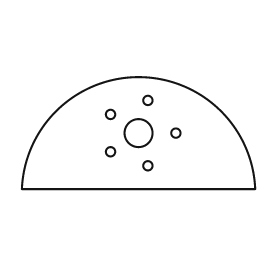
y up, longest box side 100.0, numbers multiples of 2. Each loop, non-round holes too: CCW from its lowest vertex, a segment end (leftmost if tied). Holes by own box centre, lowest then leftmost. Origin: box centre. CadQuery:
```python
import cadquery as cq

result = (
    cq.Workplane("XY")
    .moveTo(-50.0, -24.0)
    .lineTo(50.0, -24.0)
    .threePointArc((0.0, 24.0), (-50.0, -24.0))
    .close()
    .moveTo(4.0, -14.0)
    .circle(2.0)
    .moveTo(-12.0, -8.0)
    .circle(2.0)
    .moveTo(0.0, 0.0)
    .circle(6.0)
    .moveTo(16.0, 0.0)
    .circle(2.0)
    .moveTo(-12.0, 8.0)
    .circle(2.0)
    .moveTo(4.0, 14.0)
    .circle(2.0)
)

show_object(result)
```